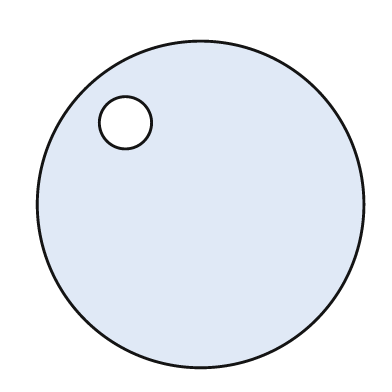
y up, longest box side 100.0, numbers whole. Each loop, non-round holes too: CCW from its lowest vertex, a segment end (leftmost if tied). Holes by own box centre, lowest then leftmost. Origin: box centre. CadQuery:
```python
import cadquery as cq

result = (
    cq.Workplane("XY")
    .moveTo(0.0, 0.0)
    .circle(50.0)
    .moveTo(-23.0, 25.0)
    .circle(8.0)
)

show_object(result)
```